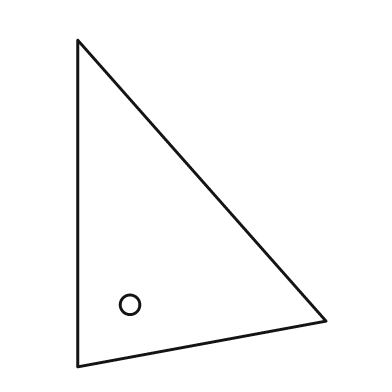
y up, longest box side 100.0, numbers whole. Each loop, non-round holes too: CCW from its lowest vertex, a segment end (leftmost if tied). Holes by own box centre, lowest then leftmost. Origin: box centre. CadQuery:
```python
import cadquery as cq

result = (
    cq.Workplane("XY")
    .moveTo(-38.0, -50.0)
    .lineTo(38.0, -36.0)
    .lineTo(-38.0, 50.0)
    .close()
    .moveTo(-22.0, -31.0)
    .circle(3.0)
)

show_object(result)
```